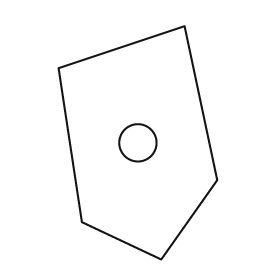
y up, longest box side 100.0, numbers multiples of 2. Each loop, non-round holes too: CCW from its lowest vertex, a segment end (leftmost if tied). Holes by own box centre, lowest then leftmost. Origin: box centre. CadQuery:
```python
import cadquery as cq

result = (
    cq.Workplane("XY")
    .moveTo(10.0, -50.0)
    .lineTo(34.0, -16.0)
    .lineTo(20.0, 50.0)
    .lineTo(-34.0, 32.0)
    .lineTo(-24.0, -34.0)
    .close()
    .moveTo(0.0, 0.0)
    .circle(8.0)
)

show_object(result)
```